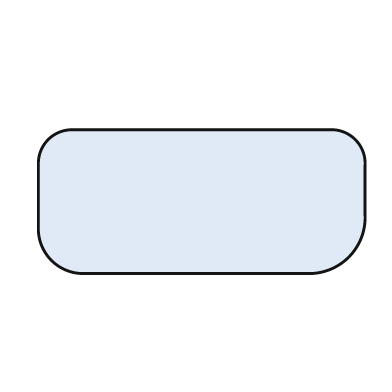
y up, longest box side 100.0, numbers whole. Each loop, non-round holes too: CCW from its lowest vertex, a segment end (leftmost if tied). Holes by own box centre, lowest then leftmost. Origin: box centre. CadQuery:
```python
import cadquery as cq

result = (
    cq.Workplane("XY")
    .moveTo(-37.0, -22.0)
    .lineTo(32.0, -22.0)
    .threePointArc((45.0, -17.0), (50.0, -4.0))
    .lineTo(50.0, 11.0)
    .threePointArc((47.0, 19.0), (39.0, 22.0))
    .lineTo(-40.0, 22.0)
    .threePointArc((-47.0, 19.0), (-50.0, 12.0))
    .lineTo(-50.0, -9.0)
    .threePointArc((-46.0, -18.0), (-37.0, -22.0))
    .close()
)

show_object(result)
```